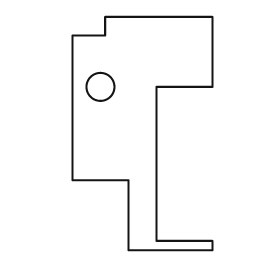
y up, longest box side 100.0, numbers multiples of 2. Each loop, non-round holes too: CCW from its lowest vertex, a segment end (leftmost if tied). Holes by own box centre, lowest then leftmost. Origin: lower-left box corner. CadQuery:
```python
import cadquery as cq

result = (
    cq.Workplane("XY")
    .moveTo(24.0, 0.0)
    .lineTo(60.0, 0.0)
    .lineTo(60.0, 4.0)
    .lineTo(36.0, 4.0)
    .lineTo(36.0, 70.0)
    .lineTo(60.0, 70.0)
    .lineTo(60.0, 100.0)
    .lineTo(14.0, 100.0)
    .lineTo(14.0, 92.0)
    .lineTo(0.0, 92.0)
    .lineTo(0.0, 30.0)
    .lineTo(24.0, 30.0)
    .close()
    .moveTo(12.0, 70.0)
    .circle(6.0)
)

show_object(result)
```